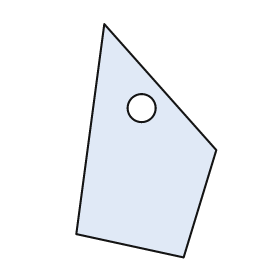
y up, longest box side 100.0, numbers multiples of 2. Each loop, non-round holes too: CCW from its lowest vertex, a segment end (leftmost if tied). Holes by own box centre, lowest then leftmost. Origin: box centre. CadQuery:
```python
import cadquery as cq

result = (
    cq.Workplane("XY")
    .moveTo(16.0, -50.0)
    .lineTo(30.0, -4.0)
    .lineTo(-18.0, 50.0)
    .lineTo(-30.0, -40.0)
    .close()
    .moveTo(-2.0, 14.0)
    .circle(6.0)
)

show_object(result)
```